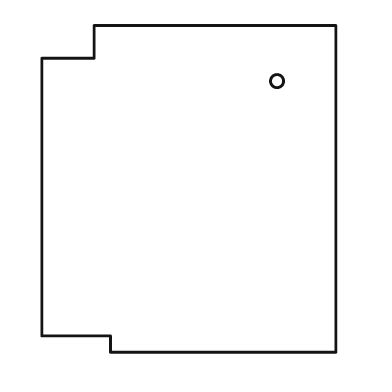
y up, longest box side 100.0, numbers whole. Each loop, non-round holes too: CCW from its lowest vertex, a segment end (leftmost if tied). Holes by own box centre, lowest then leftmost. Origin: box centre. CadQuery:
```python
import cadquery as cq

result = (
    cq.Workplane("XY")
    .moveTo(-24.0, -50.0)
    .lineTo(45.0, -50.0)
    .lineTo(45.0, 50.0)
    .lineTo(-29.0, 50.0)
    .lineTo(-29.0, 40.0)
    .lineTo(-45.0, 40.0)
    .lineTo(-45.0, -45.0)
    .lineTo(-24.0, -45.0)
    .close()
    .moveTo(27.0, 33.0)
    .circle(2.0)
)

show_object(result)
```